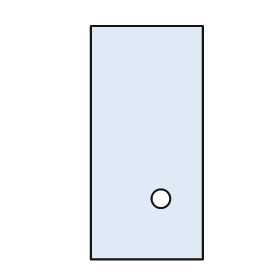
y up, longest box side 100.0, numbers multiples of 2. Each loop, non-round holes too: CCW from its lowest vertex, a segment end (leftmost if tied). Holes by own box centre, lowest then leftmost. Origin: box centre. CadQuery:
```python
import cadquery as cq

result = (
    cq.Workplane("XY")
    .moveTo(-24.0, -50.0)
    .lineTo(24.0, -50.0)
    .lineTo(24.0, 50.0)
    .lineTo(-24.0, 50.0)
    .close()
    .moveTo(6.0, -24.0)
    .circle(4.0)
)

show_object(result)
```